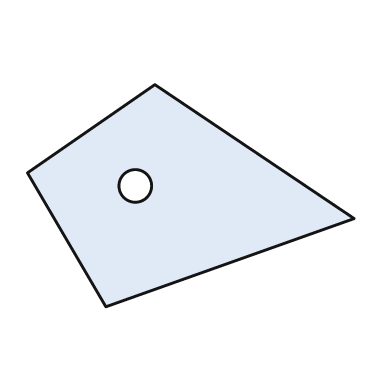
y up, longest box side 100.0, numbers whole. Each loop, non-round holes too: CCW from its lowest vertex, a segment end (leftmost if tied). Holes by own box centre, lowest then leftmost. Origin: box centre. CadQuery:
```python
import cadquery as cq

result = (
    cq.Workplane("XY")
    .moveTo(-26.0, -34.0)
    .lineTo(50.0, -7.0)
    .lineTo(-11.0, 34.0)
    .lineTo(-50.0, 7.0)
    .close()
    .moveTo(-17.0, 3.0)
    .circle(5.0)
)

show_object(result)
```